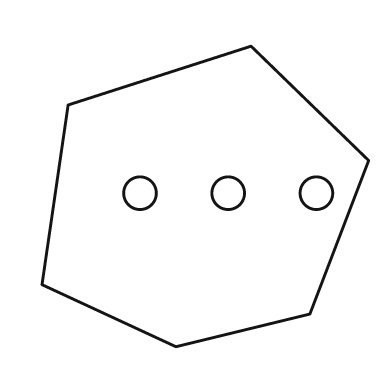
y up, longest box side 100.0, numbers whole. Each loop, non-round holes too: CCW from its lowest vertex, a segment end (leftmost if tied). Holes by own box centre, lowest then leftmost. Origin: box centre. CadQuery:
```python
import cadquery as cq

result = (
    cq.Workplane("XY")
    .moveTo(-9.0, -46.0)
    .lineTo(32.0, -36.0)
    .lineTo(50.0, 11.0)
    .lineTo(14.0, 46.0)
    .lineTo(-42.0, 28.0)
    .lineTo(-50.0, -27.0)
    .close()
    .moveTo(-20.0, 1.0)
    .circle(5.0)
    .moveTo(7.0, 1.0)
    .circle(5.0)
    .moveTo(34.0, 1.0)
    .circle(5.0)
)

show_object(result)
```